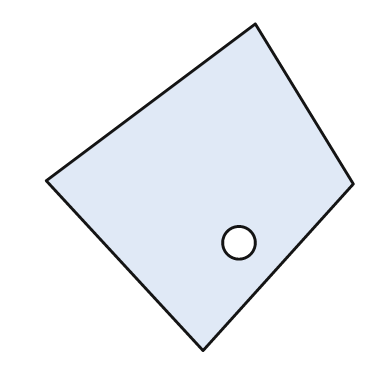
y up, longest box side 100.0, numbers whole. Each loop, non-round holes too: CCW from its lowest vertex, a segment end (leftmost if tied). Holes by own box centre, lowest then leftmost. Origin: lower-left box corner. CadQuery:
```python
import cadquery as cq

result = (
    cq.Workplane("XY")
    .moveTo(48.0, 0.0)
    .lineTo(94.0, 51.0)
    .lineTo(64.0, 100.0)
    .lineTo(0.0, 52.0)
    .close()
    .moveTo(59.0, 33.0)
    .circle(5.0)
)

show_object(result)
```